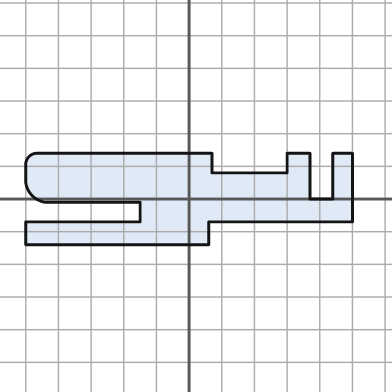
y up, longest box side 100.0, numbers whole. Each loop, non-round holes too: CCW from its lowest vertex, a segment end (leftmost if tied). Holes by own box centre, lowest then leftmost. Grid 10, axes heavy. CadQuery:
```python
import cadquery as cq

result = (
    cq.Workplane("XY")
    .moveTo(-50.0, -14.0)
    .lineTo(6.0, -14.0)
    .lineTo(6.0, -7.0)
    .lineTo(50.0, -7.0)
    .lineTo(50.0, 14.0)
    .lineTo(44.0, 14.0)
    .lineTo(44.0, 0.0)
    .lineTo(37.0, 0.0)
    .lineTo(37.0, 14.0)
    .lineTo(30.0, 14.0)
    .lineTo(30.0, 8.0)
    .lineTo(7.0, 8.0)
    .lineTo(7.0, 14.0)
    .lineTo(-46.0, 14.0)
    .threePointArc((-49.0, 13.0), (-50.0, 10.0))
    .lineTo(-50.0, 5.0)
    .threePointArc((-48.0, 1.0), (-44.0, -1.0))
    .lineTo(-15.0, -1.0)
    .lineTo(-15.0, -7.0)
    .lineTo(-50.0, -7.0)
    .close()
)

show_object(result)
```